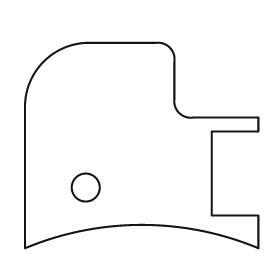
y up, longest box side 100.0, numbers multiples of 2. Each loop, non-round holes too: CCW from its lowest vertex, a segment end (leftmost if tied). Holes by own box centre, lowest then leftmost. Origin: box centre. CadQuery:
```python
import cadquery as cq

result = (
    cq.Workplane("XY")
    .moveTo(-50.0, -44.0)
    .threePointArc((0.0, -34.0), (50.0, -44.0))
    .lineTo(50.0, -30.0)
    .lineTo(30.0, -30.0)
    .lineTo(30.0, 6.0)
    .lineTo(50.0, 6.0)
    .lineTo(50.0, 12.0)
    .lineTo(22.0, 12.0)
    .threePointArc((16.0, 14.0), (14.0, 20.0))
    .lineTo(14.0, 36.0)
    .threePointArc((12.0, 42.0), (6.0, 44.0))
    .lineTo(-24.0, 44.0)
    .threePointArc((-42.0, 36.0), (-50.0, 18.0))
    .close()
    .moveTo(-24.0, -18.0)
    .circle(6.0)
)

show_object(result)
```